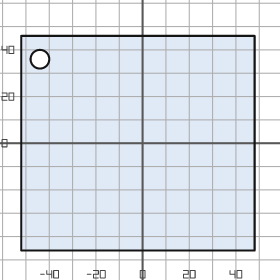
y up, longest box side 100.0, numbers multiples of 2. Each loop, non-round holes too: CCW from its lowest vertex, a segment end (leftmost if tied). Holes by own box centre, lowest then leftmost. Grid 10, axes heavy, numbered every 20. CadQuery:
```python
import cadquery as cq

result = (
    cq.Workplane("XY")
    .moveTo(-52.0, -46.0)
    .lineTo(48.0, -46.0)
    .lineTo(48.0, 46.0)
    .lineTo(-52.0, 46.0)
    .close()
    .moveTo(-44.0, 36.0)
    .circle(4.0)
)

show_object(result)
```